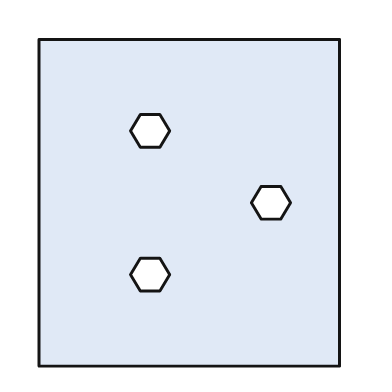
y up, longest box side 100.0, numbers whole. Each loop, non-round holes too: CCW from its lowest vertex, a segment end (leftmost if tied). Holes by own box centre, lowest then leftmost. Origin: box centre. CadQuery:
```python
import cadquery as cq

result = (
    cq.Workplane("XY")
    .moveTo(-46.0, -50.0)
    .lineTo(46.0, -50.0)
    .lineTo(46.0, 50.0)
    .lineTo(-46.0, 50.0)
    .close()
    .moveTo(-15.0, -27.0)
    .lineTo(-9.0, -27.0)
    .lineTo(-6.0, -22.0)
    .lineTo(-9.0, -17.0)
    .lineTo(-15.0, -17.0)
    .lineTo(-18.0, -22.0)
    .close()
    .moveTo(22.0, -5.0)
    .lineTo(28.0, -5.0)
    .lineTo(31.0, 0.0)
    .lineTo(28.0, 5.0)
    .lineTo(22.0, 5.0)
    .lineTo(19.0, 0.0)
    .close()
    .moveTo(-15.0, 17.0)
    .lineTo(-9.0, 17.0)
    .lineTo(-6.0, 22.0)
    .lineTo(-9.0, 27.0)
    .lineTo(-15.0, 27.0)
    .lineTo(-18.0, 22.0)
    .close()
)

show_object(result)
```